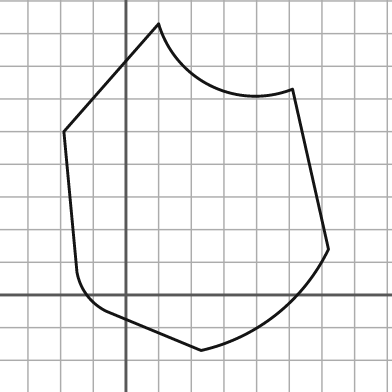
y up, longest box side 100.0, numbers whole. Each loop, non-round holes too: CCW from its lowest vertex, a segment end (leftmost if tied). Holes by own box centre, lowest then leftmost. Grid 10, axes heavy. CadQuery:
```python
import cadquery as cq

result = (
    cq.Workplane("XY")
    .moveTo(23.0, -17.0)
    .threePointArc((46.0, -6.0), (62.0, 14.0))
    .lineTo(51.0, 63.0)
    .threePointArc((26.0, 64.0), (10.0, 83.0))
    .lineTo(-19.0, 50.0)
    .lineTo(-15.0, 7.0)
    .threePointArc((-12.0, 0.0), (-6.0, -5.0))
    .close()
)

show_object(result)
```